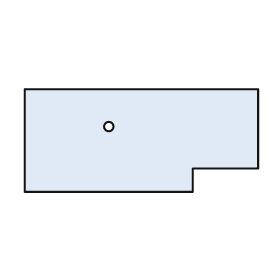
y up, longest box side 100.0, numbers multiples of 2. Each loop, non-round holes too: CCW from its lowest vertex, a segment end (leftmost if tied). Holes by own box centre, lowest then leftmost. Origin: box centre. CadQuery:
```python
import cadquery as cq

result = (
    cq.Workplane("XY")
    .moveTo(-50.0, -22.0)
    .lineTo(22.0, -22.0)
    .lineTo(22.0, -12.0)
    .lineTo(50.0, -12.0)
    .lineTo(50.0, 22.0)
    .lineTo(-50.0, 22.0)
    .close()
    .moveTo(-14.0, 6.0)
    .circle(2.0)
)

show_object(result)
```